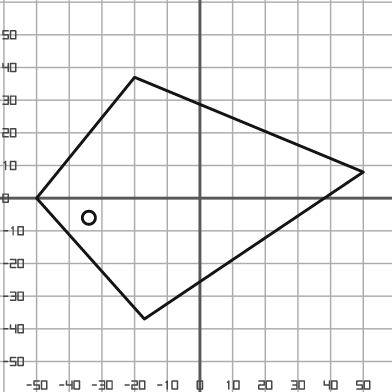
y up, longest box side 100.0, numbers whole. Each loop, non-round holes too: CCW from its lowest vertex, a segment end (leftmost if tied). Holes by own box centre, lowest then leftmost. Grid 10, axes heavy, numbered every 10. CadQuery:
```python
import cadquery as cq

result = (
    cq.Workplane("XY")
    .moveTo(-17.0, -37.0)
    .lineTo(50.0, 8.0)
    .lineTo(-20.0, 37.0)
    .lineTo(-50.0, 0.0)
    .close()
    .moveTo(-34.0, -6.0)
    .circle(2.0)
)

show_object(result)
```